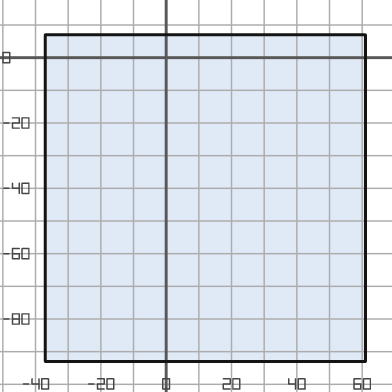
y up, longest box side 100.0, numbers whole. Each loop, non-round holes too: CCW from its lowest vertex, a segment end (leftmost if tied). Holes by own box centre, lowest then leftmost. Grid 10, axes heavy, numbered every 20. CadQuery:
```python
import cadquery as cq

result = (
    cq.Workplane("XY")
    .moveTo(-37.0, -93.0)
    .lineTo(61.0, -93.0)
    .lineTo(61.0, 7.0)
    .lineTo(-37.0, 7.0)
    .close()
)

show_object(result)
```